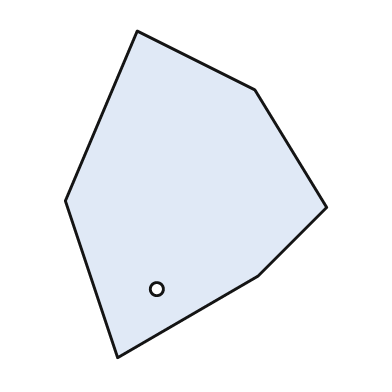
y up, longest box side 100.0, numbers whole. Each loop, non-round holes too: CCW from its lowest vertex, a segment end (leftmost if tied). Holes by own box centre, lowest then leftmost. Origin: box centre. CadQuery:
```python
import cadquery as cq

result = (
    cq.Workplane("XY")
    .moveTo(-24.0, -50.0)
    .lineTo(19.0, -25.0)
    .lineTo(40.0, -4.0)
    .lineTo(18.0, 32.0)
    .lineTo(-18.0, 50.0)
    .lineTo(-40.0, -2.0)
    .close()
    .moveTo(-12.0, -29.0)
    .circle(2.0)
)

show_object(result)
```